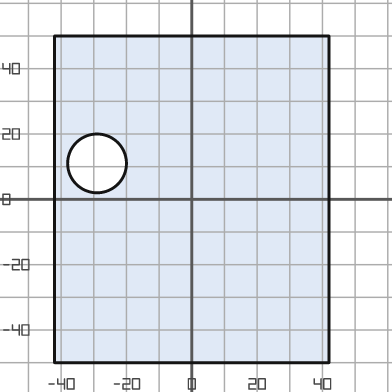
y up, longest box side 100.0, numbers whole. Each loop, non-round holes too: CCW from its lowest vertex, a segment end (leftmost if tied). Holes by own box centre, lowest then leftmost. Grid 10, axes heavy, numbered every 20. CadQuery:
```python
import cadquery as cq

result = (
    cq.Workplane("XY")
    .moveTo(-42.0, -50.0)
    .lineTo(42.0, -50.0)
    .lineTo(42.0, 50.0)
    .lineTo(-42.0, 50.0)
    .close()
    .moveTo(-29.0, 11.0)
    .circle(9.0)
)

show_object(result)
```